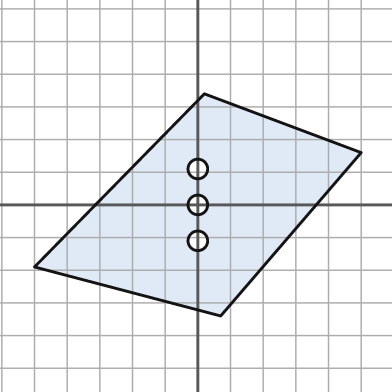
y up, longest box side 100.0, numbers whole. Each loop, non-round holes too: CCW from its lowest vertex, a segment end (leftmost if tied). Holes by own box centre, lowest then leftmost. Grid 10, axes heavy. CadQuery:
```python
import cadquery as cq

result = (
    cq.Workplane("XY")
    .moveTo(7.0, -34.0)
    .lineTo(50.0, 16.0)
    .lineTo(2.0, 34.0)
    .lineTo(-50.0, -19.0)
    .close()
    .moveTo(0.0, -11.0)
    .circle(3.0)
    .moveTo(0.0, 0.0)
    .circle(3.0)
    .moveTo(0.0, 11.0)
    .circle(3.0)
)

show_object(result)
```